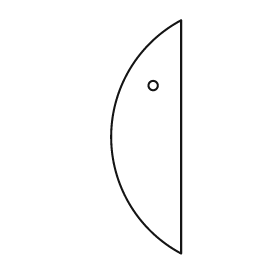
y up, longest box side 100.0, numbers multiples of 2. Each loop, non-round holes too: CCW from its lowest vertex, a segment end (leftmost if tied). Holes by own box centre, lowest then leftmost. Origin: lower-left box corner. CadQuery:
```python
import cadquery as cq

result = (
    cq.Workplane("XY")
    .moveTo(30.0, 0.0)
    .lineTo(30.0, 100.0)
    .threePointArc((0.0, 50.0), (30.0, 0.0))
    .close()
    .moveTo(18.0, 72.0)
    .circle(2.0)
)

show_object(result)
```